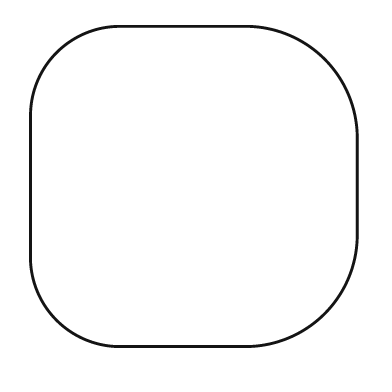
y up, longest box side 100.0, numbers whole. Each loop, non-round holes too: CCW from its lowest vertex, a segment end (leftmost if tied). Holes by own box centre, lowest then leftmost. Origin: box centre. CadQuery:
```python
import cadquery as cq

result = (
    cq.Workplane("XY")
    .moveTo(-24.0, -49.0)
    .lineTo(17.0, -49.0)
    .threePointArc((40.0, -39.0), (50.0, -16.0))
    .lineTo(50.0, 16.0)
    .threePointArc((40.0, 39.0), (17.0, 49.0))
    .lineTo(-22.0, 49.0)
    .threePointArc((-42.0, 41.0), (-50.0, 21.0))
    .lineTo(-50.0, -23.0)
    .threePointArc((-42.0, -41.0), (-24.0, -49.0))
    .close()
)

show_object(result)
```